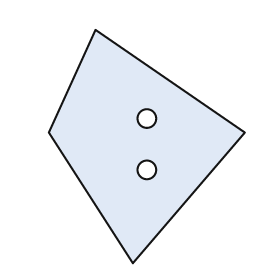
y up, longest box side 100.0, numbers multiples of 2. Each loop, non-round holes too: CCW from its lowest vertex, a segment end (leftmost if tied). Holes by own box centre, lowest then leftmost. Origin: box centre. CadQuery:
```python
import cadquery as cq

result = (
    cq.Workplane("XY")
    .moveTo(-6.0, -50.0)
    .lineTo(42.0, 6.0)
    .lineTo(-22.0, 50.0)
    .lineTo(-42.0, 6.0)
    .close()
    .moveTo(0.0, -10.0)
    .circle(4.0)
    .moveTo(0.0, 12.0)
    .circle(4.0)
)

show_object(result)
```